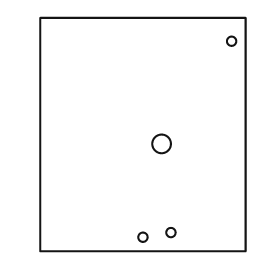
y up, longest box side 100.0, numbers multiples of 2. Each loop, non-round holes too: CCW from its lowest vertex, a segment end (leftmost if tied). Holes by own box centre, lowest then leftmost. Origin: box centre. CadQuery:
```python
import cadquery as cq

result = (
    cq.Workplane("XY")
    .moveTo(-44.0, -50.0)
    .lineTo(44.0, -50.0)
    .lineTo(44.0, 50.0)
    .lineTo(-44.0, 50.0)
    .close()
    .moveTo(0.0, -44.0)
    .circle(2.0)
    .moveTo(12.0, -42.0)
    .circle(2.0)
    .moveTo(8.0, -4.0)
    .circle(4.0)
    .moveTo(38.0, 40.0)
    .circle(2.0)
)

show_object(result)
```